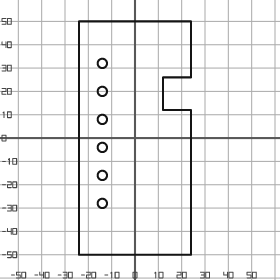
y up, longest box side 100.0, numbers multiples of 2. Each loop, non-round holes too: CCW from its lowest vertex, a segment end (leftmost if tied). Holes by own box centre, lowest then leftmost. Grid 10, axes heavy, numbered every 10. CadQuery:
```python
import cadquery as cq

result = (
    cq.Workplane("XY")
    .moveTo(-24.0, -50.0)
    .lineTo(24.0, -50.0)
    .lineTo(24.0, 12.0)
    .lineTo(12.0, 12.0)
    .lineTo(12.0, 26.0)
    .lineTo(24.0, 26.0)
    .lineTo(24.0, 50.0)
    .lineTo(-24.0, 50.0)
    .close()
    .moveTo(-14.0, -28.0)
    .circle(2.0)
    .moveTo(-14.0, -16.0)
    .circle(2.0)
    .moveTo(-14.0, -4.0)
    .circle(2.0)
    .moveTo(-14.0, 8.0)
    .circle(2.0)
    .moveTo(-14.0, 20.0)
    .circle(2.0)
    .moveTo(-14.0, 32.0)
    .circle(2.0)
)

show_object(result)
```